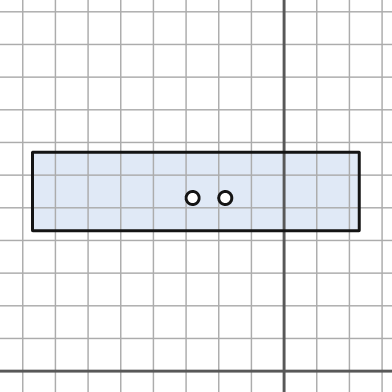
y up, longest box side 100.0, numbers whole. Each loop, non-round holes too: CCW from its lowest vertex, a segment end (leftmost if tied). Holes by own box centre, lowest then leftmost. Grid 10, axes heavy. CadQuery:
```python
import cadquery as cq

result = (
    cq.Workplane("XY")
    .moveTo(-77.0, 43.0)
    .lineTo(23.0, 43.0)
    .lineTo(23.0, 67.0)
    .lineTo(-77.0, 67.0)
    .close()
    .moveTo(-28.0, 53.0)
    .circle(2.0)
    .moveTo(-18.0, 53.0)
    .circle(2.0)
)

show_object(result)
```